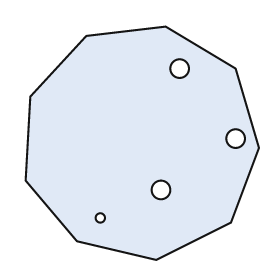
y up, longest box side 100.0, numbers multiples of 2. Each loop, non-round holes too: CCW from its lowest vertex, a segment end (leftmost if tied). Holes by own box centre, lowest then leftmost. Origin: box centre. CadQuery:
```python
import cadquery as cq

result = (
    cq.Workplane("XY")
    .moveTo(6.0, -50.0)
    .lineTo(38.0, -34.0)
    .lineTo(50.0, -2.0)
    .lineTo(40.0, 32.0)
    .lineTo(10.0, 50.0)
    .lineTo(-24.0, 46.0)
    .lineTo(-48.0, 20.0)
    .lineTo(-50.0, -16.0)
    .lineTo(-28.0, -42.0)
    .close()
    .moveTo(-18.0, -32.0)
    .circle(2.0)
    .moveTo(8.0, -20.0)
    .circle(4.0)
    .moveTo(40.0, 2.0)
    .circle(4.0)
    .moveTo(16.0, 32.0)
    .circle(4.0)
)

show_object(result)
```